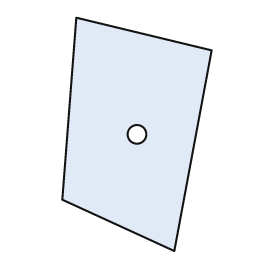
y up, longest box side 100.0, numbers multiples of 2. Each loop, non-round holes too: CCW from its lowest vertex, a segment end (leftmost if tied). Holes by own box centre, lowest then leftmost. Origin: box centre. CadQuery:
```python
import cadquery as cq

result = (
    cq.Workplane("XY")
    .moveTo(16.0, -50.0)
    .lineTo(32.0, 36.0)
    .lineTo(-26.0, 50.0)
    .lineTo(-32.0, -28.0)
    .close()
    .moveTo(0.0, 0.0)
    .circle(4.0)
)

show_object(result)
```